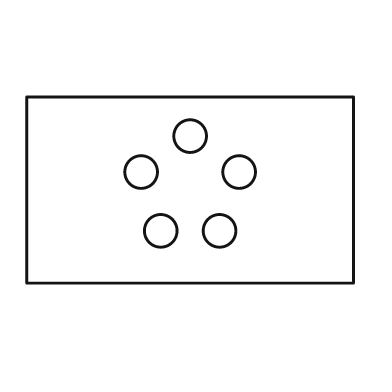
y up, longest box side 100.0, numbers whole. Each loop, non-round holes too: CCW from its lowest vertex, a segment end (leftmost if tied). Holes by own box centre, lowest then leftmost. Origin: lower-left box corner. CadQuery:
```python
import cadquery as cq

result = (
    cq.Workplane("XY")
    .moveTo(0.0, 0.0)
    .lineTo(100.0, 0.0)
    .lineTo(100.0, 57.0)
    .lineTo(0.0, 57.0)
    .close()
    .moveTo(41.0, 16.0)
    .circle(5.0)
    .moveTo(59.0, 16.0)
    .circle(5.0)
    .moveTo(35.0, 34.0)
    .circle(5.0)
    .moveTo(65.0, 34.0)
    .circle(5.0)
    .moveTo(50.0, 45.0)
    .circle(5.0)
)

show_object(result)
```